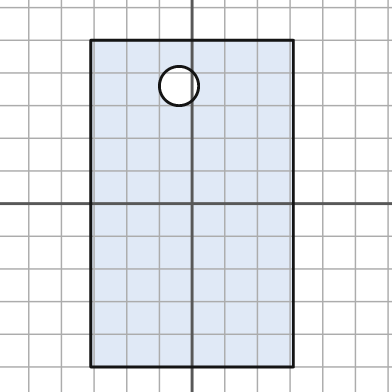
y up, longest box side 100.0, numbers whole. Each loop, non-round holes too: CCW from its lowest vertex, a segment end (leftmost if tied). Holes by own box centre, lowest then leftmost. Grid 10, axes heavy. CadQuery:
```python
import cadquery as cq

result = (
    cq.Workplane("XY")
    .moveTo(-31.0, -50.0)
    .lineTo(31.0, -50.0)
    .lineTo(31.0, 50.0)
    .lineTo(-31.0, 50.0)
    .close()
    .moveTo(-4.0, 36.0)
    .circle(6.0)
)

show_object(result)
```